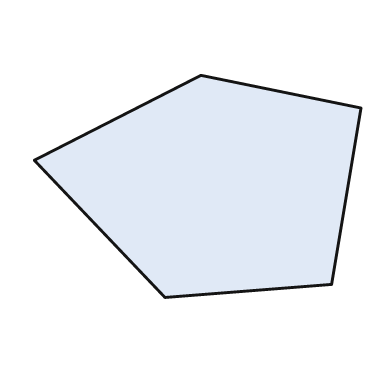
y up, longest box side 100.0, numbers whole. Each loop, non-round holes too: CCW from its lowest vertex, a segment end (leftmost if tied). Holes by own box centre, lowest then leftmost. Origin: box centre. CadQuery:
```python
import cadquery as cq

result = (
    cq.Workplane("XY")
    .moveTo(-10.0, -34.0)
    .lineTo(41.0, -30.0)
    .lineTo(50.0, 24.0)
    .lineTo(1.0, 34.0)
    .lineTo(-50.0, 8.0)
    .close()
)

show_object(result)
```